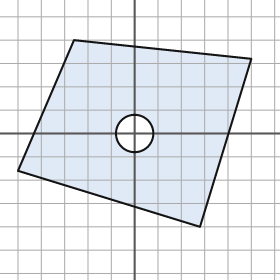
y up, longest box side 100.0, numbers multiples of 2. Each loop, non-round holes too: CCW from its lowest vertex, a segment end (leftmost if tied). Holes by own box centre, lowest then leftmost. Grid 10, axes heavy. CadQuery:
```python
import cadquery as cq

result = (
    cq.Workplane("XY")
    .moveTo(28.0, -40.0)
    .lineTo(50.0, 32.0)
    .lineTo(-26.0, 40.0)
    .lineTo(-50.0, -16.0)
    .close()
    .moveTo(0.0, 0.0)
    .circle(8.0)
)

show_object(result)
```